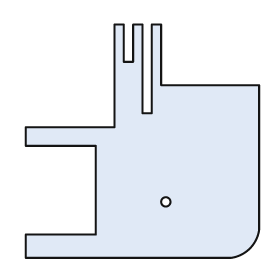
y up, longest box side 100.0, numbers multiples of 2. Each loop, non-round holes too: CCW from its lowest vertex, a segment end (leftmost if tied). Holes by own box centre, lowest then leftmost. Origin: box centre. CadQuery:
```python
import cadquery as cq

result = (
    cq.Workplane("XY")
    .moveTo(-50.0, -50.0)
    .lineTo(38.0, -50.0)
    .threePointArc((46.0, -46.0), (50.0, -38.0))
    .lineTo(50.0, 24.0)
    .lineTo(8.0, 24.0)
    .lineTo(8.0, 50.0)
    .lineTo(4.0, 50.0)
    .lineTo(4.0, 12.0)
    .lineTo(0.0, 12.0)
    .lineTo(0.0, 50.0)
    .lineTo(-4.0, 50.0)
    .lineTo(-4.0, 34.0)
    .lineTo(-8.0, 34.0)
    .lineTo(-8.0, 50.0)
    .lineTo(-12.0, 50.0)
    .lineTo(-12.0, 6.0)
    .lineTo(-50.0, 6.0)
    .lineTo(-50.0, -2.0)
    .lineTo(-20.0, -2.0)
    .lineTo(-20.0, -40.0)
    .lineTo(-50.0, -40.0)
    .close()
    .moveTo(10.0, -26.0)
    .circle(2.0)
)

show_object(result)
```